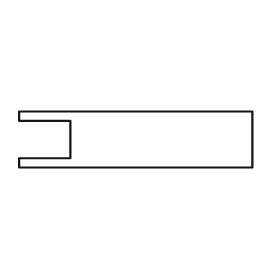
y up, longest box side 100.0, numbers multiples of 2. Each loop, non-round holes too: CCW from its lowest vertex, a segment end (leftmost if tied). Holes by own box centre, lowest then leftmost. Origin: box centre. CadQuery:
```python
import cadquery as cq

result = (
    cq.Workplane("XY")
    .moveTo(-50.0, -12.0)
    .lineTo(50.0, -12.0)
    .lineTo(50.0, 12.0)
    .lineTo(-50.0, 12.0)
    .lineTo(-50.0, 8.0)
    .lineTo(-28.0, 8.0)
    .lineTo(-28.0, -8.0)
    .lineTo(-50.0, -8.0)
    .close()
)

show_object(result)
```